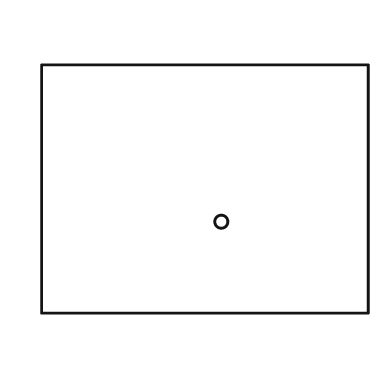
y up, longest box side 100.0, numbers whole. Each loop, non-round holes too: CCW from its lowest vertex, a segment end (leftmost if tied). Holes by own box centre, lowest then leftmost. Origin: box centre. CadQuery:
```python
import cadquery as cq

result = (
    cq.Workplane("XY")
    .moveTo(-50.0, -38.0)
    .lineTo(50.0, -38.0)
    .lineTo(50.0, 38.0)
    .lineTo(-50.0, 38.0)
    .close()
    .moveTo(5.0, -10.0)
    .circle(2.0)
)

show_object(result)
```